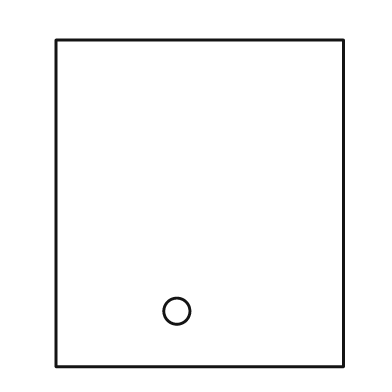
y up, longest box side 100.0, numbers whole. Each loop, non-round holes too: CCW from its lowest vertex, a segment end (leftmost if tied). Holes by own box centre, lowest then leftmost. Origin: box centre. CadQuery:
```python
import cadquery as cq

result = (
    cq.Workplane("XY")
    .moveTo(-44.0, -50.0)
    .lineTo(44.0, -50.0)
    .lineTo(44.0, 50.0)
    .lineTo(-44.0, 50.0)
    .close()
    .moveTo(-7.0, -33.0)
    .circle(4.0)
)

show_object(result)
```